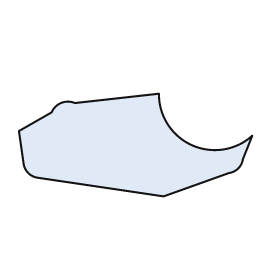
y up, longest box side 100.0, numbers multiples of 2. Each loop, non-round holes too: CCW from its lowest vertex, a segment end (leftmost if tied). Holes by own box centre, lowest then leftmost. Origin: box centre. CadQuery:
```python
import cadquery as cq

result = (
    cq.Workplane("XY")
    .moveTo(12.0, -22.0)
    .lineTo(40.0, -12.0)
    .threePointArc((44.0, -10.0), (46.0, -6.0))
    .lineTo(50.0, 4.0)
    .threePointArc((24.0, 0.0), (10.0, 22.0))
    .lineTo(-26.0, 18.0)
    .threePointArc((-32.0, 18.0), (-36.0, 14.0))
    .lineTo(-50.0, 6.0)
    .lineTo(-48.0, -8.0)
    .threePointArc((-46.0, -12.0), (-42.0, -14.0))
    .close()
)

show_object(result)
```